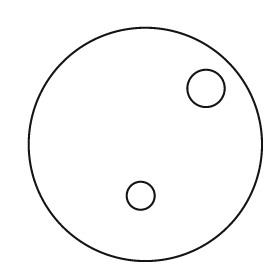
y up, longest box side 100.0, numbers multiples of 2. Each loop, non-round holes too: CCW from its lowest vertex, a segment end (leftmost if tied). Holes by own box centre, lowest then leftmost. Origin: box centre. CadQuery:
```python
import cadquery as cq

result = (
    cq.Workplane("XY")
    .moveTo(0.0, 0.0)
    .circle(50.0)
    .moveTo(-2.0, -22.0)
    .circle(6.0)
    .moveTo(26.0, 24.0)
    .circle(8.0)
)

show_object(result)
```